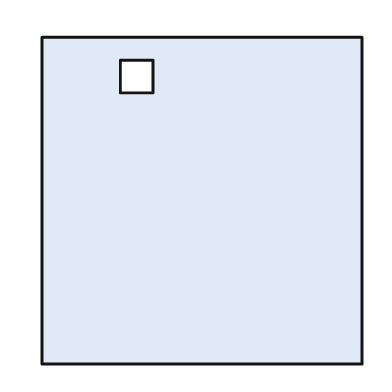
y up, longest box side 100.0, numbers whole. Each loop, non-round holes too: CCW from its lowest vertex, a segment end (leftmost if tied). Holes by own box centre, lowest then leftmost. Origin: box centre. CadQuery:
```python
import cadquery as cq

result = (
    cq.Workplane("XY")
    .moveTo(-49.0, -50.0)
    .lineTo(49.0, -50.0)
    .lineTo(49.0, 50.0)
    .lineTo(-49.0, 50.0)
    .close()
    .moveTo(-25.0, 33.0)
    .lineTo(-15.0, 33.0)
    .lineTo(-15.0, 43.0)
    .lineTo(-25.0, 43.0)
    .close()
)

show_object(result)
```